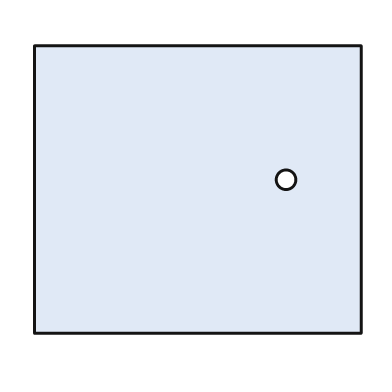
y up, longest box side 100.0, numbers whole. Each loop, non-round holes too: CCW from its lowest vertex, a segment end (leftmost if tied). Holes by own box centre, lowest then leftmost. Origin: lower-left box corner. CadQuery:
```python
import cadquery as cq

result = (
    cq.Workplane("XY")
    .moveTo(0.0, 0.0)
    .lineTo(100.0, 0.0)
    .lineTo(100.0, 88.0)
    .lineTo(0.0, 88.0)
    .close()
    .moveTo(77.0, 47.0)
    .circle(3.0)
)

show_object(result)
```